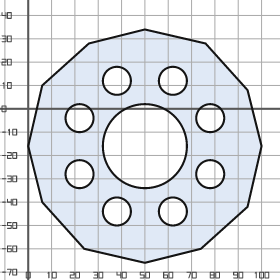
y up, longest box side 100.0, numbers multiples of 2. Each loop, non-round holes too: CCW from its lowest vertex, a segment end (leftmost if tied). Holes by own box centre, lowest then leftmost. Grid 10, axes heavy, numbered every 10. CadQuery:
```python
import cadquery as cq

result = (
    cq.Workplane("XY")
    .moveTo(50.0, -66.0)
    .lineTo(74.0, -60.0)
    .lineTo(94.0, -42.0)
    .lineTo(100.0, -16.0)
    .lineTo(94.0, 8.0)
    .lineTo(76.0, 28.0)
    .lineTo(50.0, 34.0)
    .lineTo(26.0, 28.0)
    .lineTo(6.0, 10.0)
    .lineTo(0.0, -16.0)
    .lineTo(6.0, -40.0)
    .lineTo(24.0, -60.0)
    .close()
    .moveTo(38.0, -44.0)
    .circle(6.0)
    .moveTo(62.0, -44.0)
    .circle(6.0)
    .moveTo(22.0, -28.0)
    .circle(6.0)
    .moveTo(78.0, -28.0)
    .circle(6.0)
    .moveTo(50.0, -16.0)
    .circle(18.0)
    .moveTo(22.0, -4.0)
    .circle(6.0)
    .moveTo(78.0, -4.0)
    .circle(6.0)
    .moveTo(38.0, 12.0)
    .circle(6.0)
    .moveTo(62.0, 12.0)
    .circle(6.0)
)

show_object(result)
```